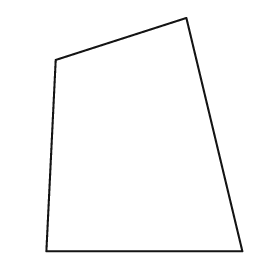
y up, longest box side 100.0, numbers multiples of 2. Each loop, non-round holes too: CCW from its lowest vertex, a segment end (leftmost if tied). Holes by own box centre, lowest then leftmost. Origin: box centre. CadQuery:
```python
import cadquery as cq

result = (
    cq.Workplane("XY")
    .moveTo(-42.0, -50.0)
    .lineTo(42.0, -50.0)
    .lineTo(18.0, 50.0)
    .lineTo(-38.0, 32.0)
    .close()
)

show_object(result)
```